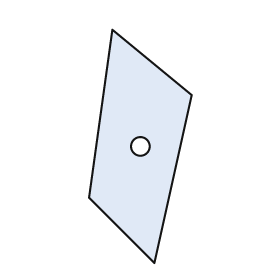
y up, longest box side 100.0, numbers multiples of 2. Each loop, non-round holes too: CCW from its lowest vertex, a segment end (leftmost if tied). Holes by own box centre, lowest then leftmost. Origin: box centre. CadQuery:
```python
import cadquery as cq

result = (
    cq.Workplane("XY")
    .moveTo(6.0, -50.0)
    .lineTo(22.0, 22.0)
    .lineTo(-12.0, 50.0)
    .lineTo(-22.0, -22.0)
    .close()
    .moveTo(0.0, 0.0)
    .circle(4.0)
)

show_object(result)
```